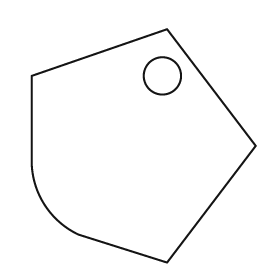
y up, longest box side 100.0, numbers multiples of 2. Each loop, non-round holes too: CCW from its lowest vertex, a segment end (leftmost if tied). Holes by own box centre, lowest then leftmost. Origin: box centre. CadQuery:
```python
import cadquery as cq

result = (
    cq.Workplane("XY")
    .moveTo(10.0, -50.0)
    .lineTo(48.0, 0.0)
    .lineTo(10.0, 50.0)
    .lineTo(-48.0, 30.0)
    .lineTo(-48.0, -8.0)
    .threePointArc((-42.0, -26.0), (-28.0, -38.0))
    .close()
    .moveTo(8.0, 30.0)
    .circle(8.0)
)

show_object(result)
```